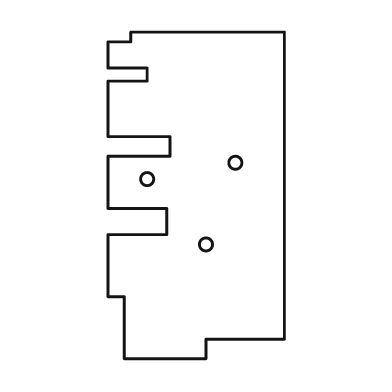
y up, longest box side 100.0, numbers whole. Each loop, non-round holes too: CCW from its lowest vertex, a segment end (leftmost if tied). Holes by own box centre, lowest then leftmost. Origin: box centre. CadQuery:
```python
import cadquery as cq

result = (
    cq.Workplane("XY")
    .moveTo(-22.0, -50.0)
    .lineTo(3.0, -50.0)
    .lineTo(3.0, -44.0)
    .lineTo(27.0, -44.0)
    .lineTo(27.0, 50.0)
    .lineTo(-20.0, 50.0)
    .lineTo(-20.0, 47.0)
    .lineTo(-27.0, 47.0)
    .lineTo(-27.0, 39.0)
    .lineTo(-15.0, 39.0)
    .lineTo(-15.0, 35.0)
    .lineTo(-27.0, 35.0)
    .lineTo(-27.0, 18.0)
    .lineTo(-8.0, 18.0)
    .lineTo(-8.0, 12.0)
    .lineTo(-27.0, 12.0)
    .lineTo(-27.0, -4.0)
    .lineTo(-9.0, -4.0)
    .lineTo(-9.0, -12.0)
    .lineTo(-27.0, -12.0)
    .lineTo(-27.0, -31.0)
    .lineTo(-22.0, -31.0)
    .close()
    .moveTo(3.0, -15.0)
    .circle(2.0)
    .moveTo(-15.0, 5.0)
    .circle(2.0)
    .moveTo(12.0, 10.0)
    .circle(2.0)
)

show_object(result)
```